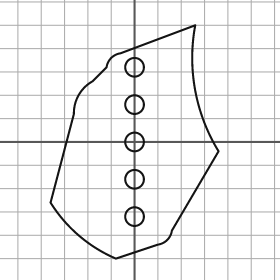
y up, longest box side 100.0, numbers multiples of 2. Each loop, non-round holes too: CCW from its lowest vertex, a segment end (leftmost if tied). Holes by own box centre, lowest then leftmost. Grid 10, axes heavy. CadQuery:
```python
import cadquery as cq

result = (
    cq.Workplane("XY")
    .moveTo(-8.0, -50.0)
    .lineTo(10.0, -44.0)
    .threePointArc((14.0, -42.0), (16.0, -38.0))
    .lineTo(36.0, -4.0)
    .threePointArc((26.0, 22.0), (26.0, 50.0))
    .lineTo(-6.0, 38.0)
    .threePointArc((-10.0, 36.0), (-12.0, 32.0))
    .lineTo(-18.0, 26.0)
    .threePointArc((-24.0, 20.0), (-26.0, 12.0))
    .lineTo(-36.0, -26.0)
    .threePointArc((-24.0, -40.0), (-8.0, -50.0))
    .close()
    .moveTo(0.0, -32.0)
    .circle(4.0)
    .moveTo(0.0, -16.0)
    .circle(4.0)
    .moveTo(0.0, 0.0)
    .circle(4.0)
    .moveTo(0.0, 16.0)
    .circle(4.0)
    .moveTo(0.0, 32.0)
    .circle(4.0)
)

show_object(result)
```